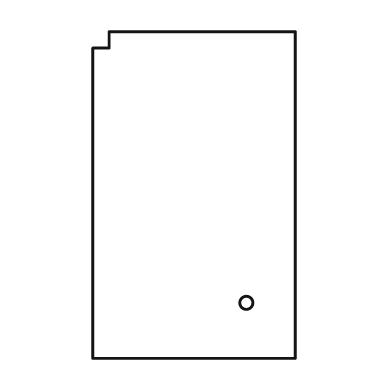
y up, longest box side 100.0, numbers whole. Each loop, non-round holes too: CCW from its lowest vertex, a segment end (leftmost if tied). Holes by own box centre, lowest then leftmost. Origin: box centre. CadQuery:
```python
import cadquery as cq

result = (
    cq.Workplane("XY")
    .moveTo(-31.0, -50.0)
    .lineTo(31.0, -50.0)
    .lineTo(31.0, 50.0)
    .lineTo(-26.0, 50.0)
    .lineTo(-26.0, 45.0)
    .lineTo(-31.0, 45.0)
    .close()
    .moveTo(16.0, -33.0)
    .circle(2.0)
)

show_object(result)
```